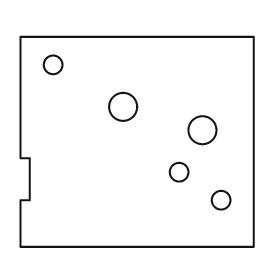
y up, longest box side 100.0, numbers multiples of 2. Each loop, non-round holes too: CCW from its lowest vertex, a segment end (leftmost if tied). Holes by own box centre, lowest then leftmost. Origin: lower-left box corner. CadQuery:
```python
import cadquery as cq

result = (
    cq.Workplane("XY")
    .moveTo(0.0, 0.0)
    .lineTo(100.0, 0.0)
    .lineTo(100.0, 90.0)
    .lineTo(0.0, 90.0)
    .lineTo(0.0, 38.0)
    .lineTo(4.0, 38.0)
    .lineTo(4.0, 20.0)
    .lineTo(0.0, 20.0)
    .close()
    .moveTo(86.0, 20.0)
    .circle(4.0)
    .moveTo(68.0, 32.0)
    .circle(4.0)
    .moveTo(78.0, 50.0)
    .circle(6.0)
    .moveTo(44.0, 60.0)
    .circle(6.0)
    .moveTo(14.0, 78.0)
    .circle(4.0)
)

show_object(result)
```